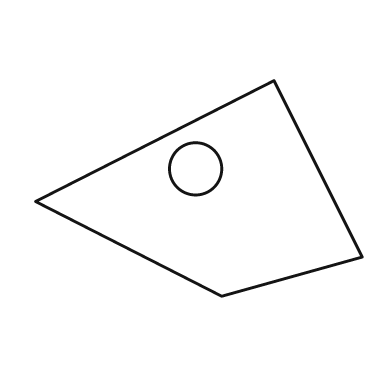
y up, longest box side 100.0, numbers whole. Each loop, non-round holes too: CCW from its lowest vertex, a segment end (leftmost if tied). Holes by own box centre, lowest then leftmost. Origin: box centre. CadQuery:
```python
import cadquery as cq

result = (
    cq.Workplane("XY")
    .moveTo(7.0, -33.0)
    .lineTo(50.0, -21.0)
    .lineTo(23.0, 33.0)
    .lineTo(-50.0, -4.0)
    .close()
    .moveTo(-1.0, 6.0)
    .circle(8.0)
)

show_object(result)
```